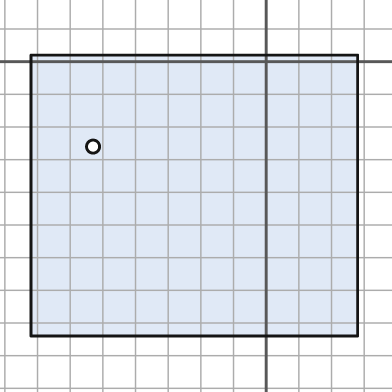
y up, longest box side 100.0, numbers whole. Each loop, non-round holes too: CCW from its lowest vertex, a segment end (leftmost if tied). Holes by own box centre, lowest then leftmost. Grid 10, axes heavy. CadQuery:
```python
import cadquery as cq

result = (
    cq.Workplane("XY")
    .moveTo(-72.0, -84.0)
    .lineTo(28.0, -84.0)
    .lineTo(28.0, 2.0)
    .lineTo(-72.0, 2.0)
    .close()
    .moveTo(-53.0, -26.0)
    .circle(2.0)
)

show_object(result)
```